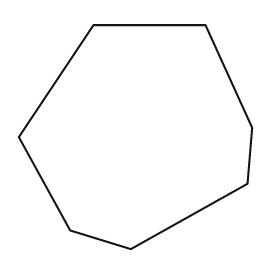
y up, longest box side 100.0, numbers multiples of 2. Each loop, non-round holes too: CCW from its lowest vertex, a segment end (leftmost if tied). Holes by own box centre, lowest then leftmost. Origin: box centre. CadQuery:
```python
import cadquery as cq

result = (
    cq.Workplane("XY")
    .moveTo(-2.0, -48.0)
    .lineTo(48.0, -20.0)
    .lineTo(50.0, 4.0)
    .lineTo(30.0, 48.0)
    .lineTo(-18.0, 48.0)
    .lineTo(-50.0, 0.0)
    .lineTo(-28.0, -40.0)
    .close()
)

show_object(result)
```